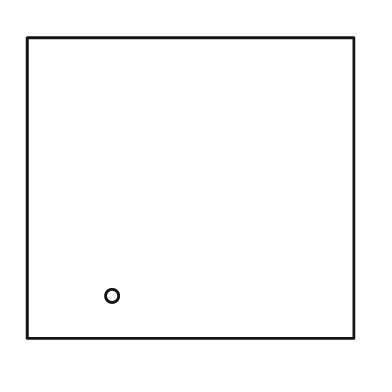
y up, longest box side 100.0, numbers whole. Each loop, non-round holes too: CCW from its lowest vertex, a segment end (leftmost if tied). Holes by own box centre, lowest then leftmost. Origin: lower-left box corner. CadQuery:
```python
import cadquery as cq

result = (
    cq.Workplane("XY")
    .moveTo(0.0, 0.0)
    .lineTo(100.0, 0.0)
    .lineTo(100.0, 92.0)
    .lineTo(0.0, 92.0)
    .close()
    .moveTo(26.0, 13.0)
    .circle(2.0)
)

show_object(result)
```